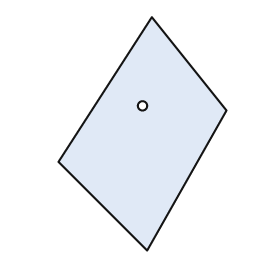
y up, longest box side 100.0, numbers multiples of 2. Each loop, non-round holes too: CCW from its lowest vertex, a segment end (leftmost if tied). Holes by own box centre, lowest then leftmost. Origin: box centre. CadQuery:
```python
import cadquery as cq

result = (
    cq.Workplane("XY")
    .moveTo(2.0, -50.0)
    .lineTo(36.0, 10.0)
    .lineTo(4.0, 50.0)
    .lineTo(-36.0, -12.0)
    .close()
    .moveTo(0.0, 12.0)
    .circle(2.0)
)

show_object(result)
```